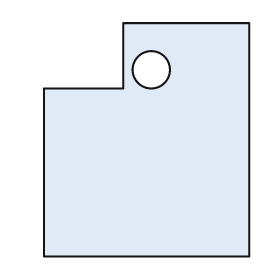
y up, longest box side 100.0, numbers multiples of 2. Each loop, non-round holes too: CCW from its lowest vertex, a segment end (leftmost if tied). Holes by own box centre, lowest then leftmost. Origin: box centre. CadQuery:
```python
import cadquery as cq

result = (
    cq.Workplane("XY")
    .moveTo(-44.0, -50.0)
    .lineTo(44.0, -50.0)
    .lineTo(44.0, 50.0)
    .lineTo(-10.0, 50.0)
    .lineTo(-10.0, 22.0)
    .lineTo(-44.0, 22.0)
    .close()
    .moveTo(2.0, 30.0)
    .circle(8.0)
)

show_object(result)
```